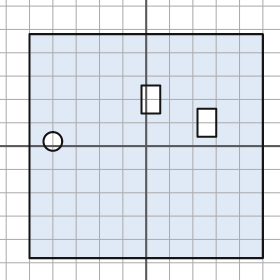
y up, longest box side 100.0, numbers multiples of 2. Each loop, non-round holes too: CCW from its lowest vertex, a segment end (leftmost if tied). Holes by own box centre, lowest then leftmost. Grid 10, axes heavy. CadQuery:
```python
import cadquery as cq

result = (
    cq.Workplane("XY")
    .moveTo(-50.0, -48.0)
    .lineTo(50.0, -48.0)
    .lineTo(50.0, 48.0)
    .lineTo(-50.0, 48.0)
    .close()
    .moveTo(-40.0, 2.0)
    .circle(4.0)
    .moveTo(22.0, 4.0)
    .lineTo(30.0, 4.0)
    .lineTo(30.0, 16.0)
    .lineTo(22.0, 16.0)
    .close()
    .moveTo(-2.0, 14.0)
    .lineTo(6.0, 14.0)
    .lineTo(6.0, 26.0)
    .lineTo(-2.0, 26.0)
    .close()
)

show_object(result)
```